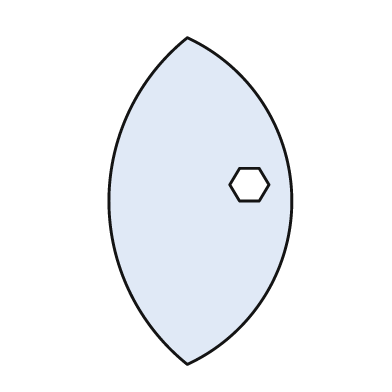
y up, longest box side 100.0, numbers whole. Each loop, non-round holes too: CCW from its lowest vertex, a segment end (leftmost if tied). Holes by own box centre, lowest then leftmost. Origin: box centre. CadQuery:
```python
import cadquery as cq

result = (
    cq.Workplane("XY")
    .moveTo(-4.0, -50.0)
    .threePointArc((28.0, 0.0), (-4.0, 50.0))
    .threePointArc((-28.0, 0.0), (-4.0, -50.0))
    .close()
    .moveTo(12.0, 0.0)
    .lineTo(18.0, 0.0)
    .lineTo(21.0, 5.0)
    .lineTo(18.0, 10.0)
    .lineTo(12.0, 10.0)
    .lineTo(9.0, 5.0)
    .close()
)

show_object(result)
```